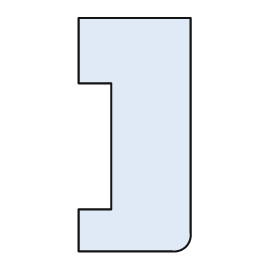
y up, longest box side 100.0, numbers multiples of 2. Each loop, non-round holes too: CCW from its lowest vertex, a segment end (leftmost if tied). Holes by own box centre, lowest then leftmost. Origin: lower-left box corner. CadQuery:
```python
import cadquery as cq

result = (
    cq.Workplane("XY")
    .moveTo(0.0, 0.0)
    .lineTo(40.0, 0.0)
    .threePointArc((46.0, 2.0), (48.0, 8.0))
    .lineTo(48.0, 100.0)
    .lineTo(0.0, 100.0)
    .lineTo(0.0, 72.0)
    .lineTo(14.0, 72.0)
    .lineTo(14.0, 18.0)
    .lineTo(0.0, 18.0)
    .close()
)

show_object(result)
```